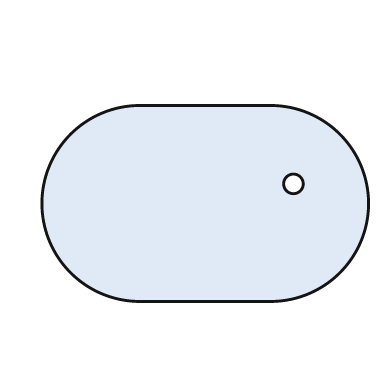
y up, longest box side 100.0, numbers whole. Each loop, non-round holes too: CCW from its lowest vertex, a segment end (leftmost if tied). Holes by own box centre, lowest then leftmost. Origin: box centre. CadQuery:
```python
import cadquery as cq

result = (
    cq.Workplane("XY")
    .moveTo(-20.0, -30.0)
    .lineTo(20.0, -30.0)
    .threePointArc((50.0, 0.0), (20.0, 30.0))
    .lineTo(-20.0, 30.0)
    .threePointArc((-50.0, 0.0), (-20.0, -30.0))
    .close()
    .moveTo(27.0, 6.0)
    .circle(3.0)
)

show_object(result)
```